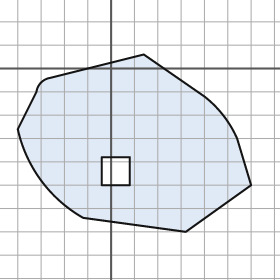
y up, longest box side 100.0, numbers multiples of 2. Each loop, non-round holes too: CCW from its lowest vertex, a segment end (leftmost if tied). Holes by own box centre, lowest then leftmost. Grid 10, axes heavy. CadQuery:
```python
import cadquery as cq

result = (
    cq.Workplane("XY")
    .moveTo(32.0, -70.0)
    .lineTo(60.0, -50.0)
    .lineTo(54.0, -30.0)
    .threePointArc((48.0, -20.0), (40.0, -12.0))
    .lineTo(14.0, 6.0)
    .lineTo(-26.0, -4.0)
    .threePointArc((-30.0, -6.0), (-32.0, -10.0))
    .lineTo(-40.0, -26.0)
    .threePointArc((-30.0, -48.0), (-12.0, -64.0))
    .close()
    .moveTo(-4.0, -50.0)
    .lineTo(8.0, -50.0)
    .lineTo(8.0, -38.0)
    .lineTo(-4.0, -38.0)
    .close()
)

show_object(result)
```